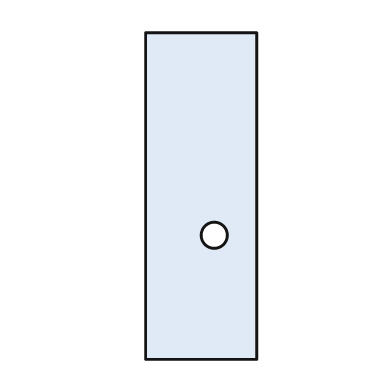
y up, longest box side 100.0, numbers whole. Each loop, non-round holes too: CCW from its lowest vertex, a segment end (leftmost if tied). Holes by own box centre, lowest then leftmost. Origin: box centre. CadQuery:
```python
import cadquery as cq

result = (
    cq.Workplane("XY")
    .moveTo(-17.0, -50.0)
    .lineTo(17.0, -50.0)
    .lineTo(17.0, 50.0)
    .lineTo(-17.0, 50.0)
    .close()
    .moveTo(4.0, -12.0)
    .circle(4.0)
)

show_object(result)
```